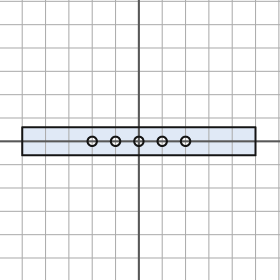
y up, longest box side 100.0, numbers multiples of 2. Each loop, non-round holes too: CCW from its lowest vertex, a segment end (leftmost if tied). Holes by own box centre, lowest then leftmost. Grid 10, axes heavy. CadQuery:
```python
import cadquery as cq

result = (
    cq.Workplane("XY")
    .moveTo(-50.0, -6.0)
    .lineTo(50.0, -6.0)
    .lineTo(50.0, 6.0)
    .lineTo(-50.0, 6.0)
    .close()
    .moveTo(-20.0, 0.0)
    .circle(2.0)
    .moveTo(-10.0, 0.0)
    .circle(2.0)
    .moveTo(0.0, 0.0)
    .circle(2.0)
    .moveTo(10.0, 0.0)
    .circle(2.0)
    .moveTo(20.0, 0.0)
    .circle(2.0)
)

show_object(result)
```